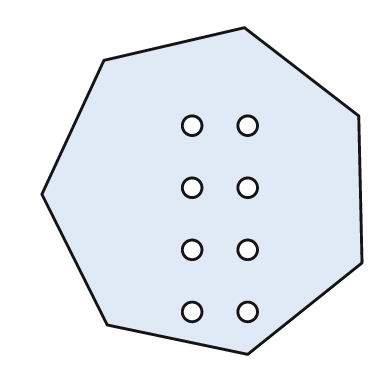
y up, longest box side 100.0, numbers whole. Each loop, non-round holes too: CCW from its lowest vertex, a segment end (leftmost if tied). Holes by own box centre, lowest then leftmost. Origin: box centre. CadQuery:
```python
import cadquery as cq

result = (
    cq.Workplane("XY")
    .moveTo(14.0, -50.0)
    .lineTo(49.0, -22.0)
    .lineTo(48.0, 23.0)
    .lineTo(13.0, 50.0)
    .lineTo(-30.0, 40.0)
    .lineTo(-49.0, -1.0)
    .lineTo(-29.0, -41.0)
    .close()
    .moveTo(-3.0, -37.0)
    .circle(3.0)
    .moveTo(14.0, -37.0)
    .circle(3.0)
    .moveTo(-3.0, -18.0)
    .circle(3.0)
    .moveTo(14.0, -18.0)
    .circle(3.0)
    .moveTo(-3.0, 1.0)
    .circle(3.0)
    .moveTo(14.0, 1.0)
    .circle(3.0)
    .moveTo(-3.0, 20.0)
    .circle(3.0)
    .moveTo(14.0, 20.0)
    .circle(3.0)
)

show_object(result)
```